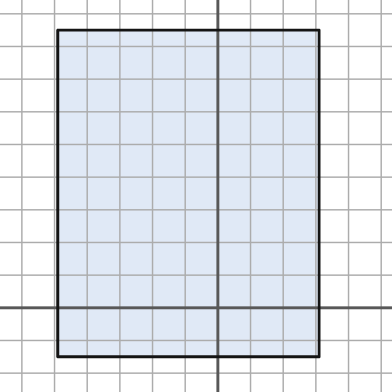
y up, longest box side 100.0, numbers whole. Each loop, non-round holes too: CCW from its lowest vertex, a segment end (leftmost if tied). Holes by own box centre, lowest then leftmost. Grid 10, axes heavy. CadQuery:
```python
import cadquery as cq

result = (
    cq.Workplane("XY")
    .moveTo(-49.0, -15.0)
    .lineTo(31.0, -15.0)
    .lineTo(31.0, 85.0)
    .lineTo(-49.0, 85.0)
    .close()
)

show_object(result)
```